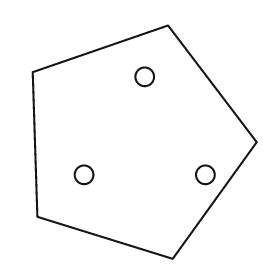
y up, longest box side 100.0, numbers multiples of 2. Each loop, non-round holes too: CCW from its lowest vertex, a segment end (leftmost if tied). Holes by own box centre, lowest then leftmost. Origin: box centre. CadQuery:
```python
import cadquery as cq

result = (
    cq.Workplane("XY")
    .moveTo(12.0, -50.0)
    .lineTo(48.0, 0.0)
    .lineTo(10.0, 50.0)
    .lineTo(-48.0, 30.0)
    .lineTo(-46.0, -32.0)
    .close()
    .moveTo(-26.0, -14.0)
    .circle(4.0)
    .moveTo(26.0, -14.0)
    .circle(4.0)
    .moveTo(0.0, 28.0)
    .circle(4.0)
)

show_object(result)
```